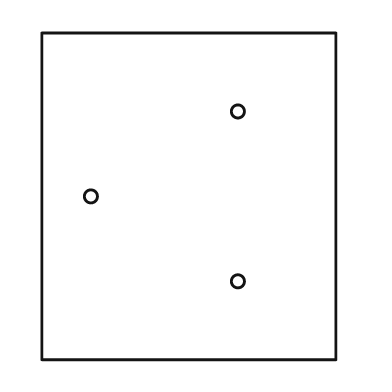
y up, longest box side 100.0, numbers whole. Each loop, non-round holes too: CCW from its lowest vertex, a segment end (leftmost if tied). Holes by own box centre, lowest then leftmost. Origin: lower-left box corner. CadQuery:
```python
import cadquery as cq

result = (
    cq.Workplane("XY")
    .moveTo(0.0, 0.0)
    .lineTo(90.0, 0.0)
    .lineTo(90.0, 100.0)
    .lineTo(0.0, 100.0)
    .close()
    .moveTo(60.0, 24.0)
    .circle(2.0)
    .moveTo(15.0, 50.0)
    .circle(2.0)
    .moveTo(60.0, 76.0)
    .circle(2.0)
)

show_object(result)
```